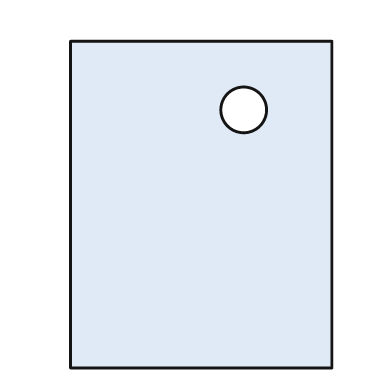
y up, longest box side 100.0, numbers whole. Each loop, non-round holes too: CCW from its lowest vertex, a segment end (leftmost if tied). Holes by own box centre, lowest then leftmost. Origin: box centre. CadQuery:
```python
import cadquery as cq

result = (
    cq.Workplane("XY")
    .moveTo(-40.0, -50.0)
    .lineTo(40.0, -50.0)
    .lineTo(40.0, 50.0)
    .lineTo(-40.0, 50.0)
    .close()
    .moveTo(13.0, 29.0)
    .circle(7.0)
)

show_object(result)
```